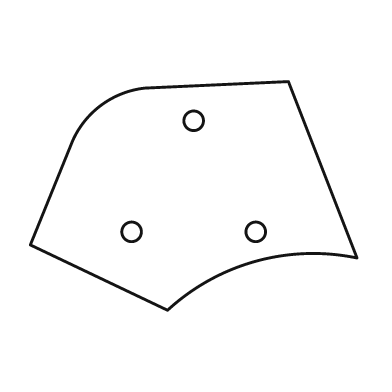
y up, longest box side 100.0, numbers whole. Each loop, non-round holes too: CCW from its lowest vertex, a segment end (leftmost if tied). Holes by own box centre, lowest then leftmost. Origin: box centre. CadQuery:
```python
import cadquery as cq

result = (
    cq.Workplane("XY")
    .moveTo(-8.0, -35.0)
    .threePointArc((19.0, -20.0), (50.0, -19.0))
    .lineTo(29.0, 35.0)
    .lineTo(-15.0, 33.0)
    .threePointArc((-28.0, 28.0), (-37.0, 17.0))
    .lineTo(-50.0, -15.0)
    .close()
    .moveTo(-19.0, -11.0)
    .circle(3.0)
    .moveTo(19.0, -11.0)
    .circle(3.0)
    .moveTo(0.0, 23.0)
    .circle(3.0)
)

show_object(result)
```